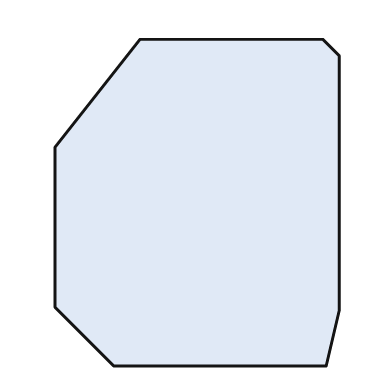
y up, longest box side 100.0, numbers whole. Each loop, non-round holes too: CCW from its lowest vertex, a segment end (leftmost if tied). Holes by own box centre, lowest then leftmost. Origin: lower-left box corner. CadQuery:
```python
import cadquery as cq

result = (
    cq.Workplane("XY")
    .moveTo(18.0, 0.0)
    .lineTo(83.0, 0.0)
    .lineTo(87.0, 17.0)
    .lineTo(87.0, 95.0)
    .lineTo(82.0, 100.0)
    .lineTo(26.0, 100.0)
    .lineTo(0.0, 67.0)
    .lineTo(0.0, 18.0)
    .close()
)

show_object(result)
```